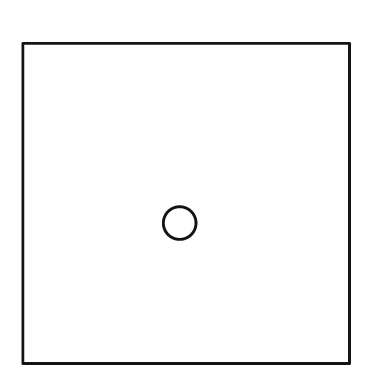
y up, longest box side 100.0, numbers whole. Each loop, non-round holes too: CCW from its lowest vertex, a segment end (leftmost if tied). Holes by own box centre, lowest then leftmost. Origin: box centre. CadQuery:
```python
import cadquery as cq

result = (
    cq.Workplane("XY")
    .moveTo(-50.0, -49.0)
    .lineTo(50.0, -49.0)
    .lineTo(50.0, 49.0)
    .lineTo(-50.0, 49.0)
    .close()
    .moveTo(-2.0, -6.0)
    .circle(5.0)
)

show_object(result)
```